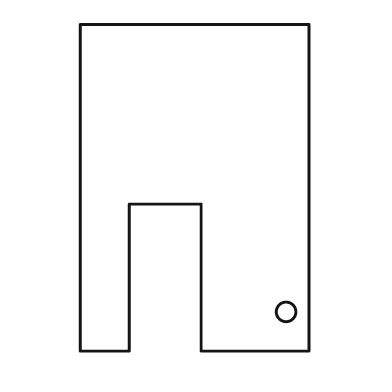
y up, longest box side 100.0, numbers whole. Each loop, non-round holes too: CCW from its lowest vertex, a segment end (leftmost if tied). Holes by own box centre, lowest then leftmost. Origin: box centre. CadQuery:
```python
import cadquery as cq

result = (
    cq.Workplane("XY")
    .moveTo(-35.0, -50.0)
    .lineTo(-20.0, -50.0)
    .lineTo(-20.0, -5.0)
    .lineTo(2.0, -5.0)
    .lineTo(2.0, -50.0)
    .lineTo(35.0, -50.0)
    .lineTo(35.0, 50.0)
    .lineTo(-35.0, 50.0)
    .close()
    .moveTo(28.0, -38.0)
    .circle(3.0)
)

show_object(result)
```